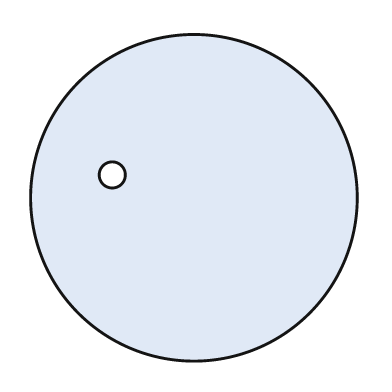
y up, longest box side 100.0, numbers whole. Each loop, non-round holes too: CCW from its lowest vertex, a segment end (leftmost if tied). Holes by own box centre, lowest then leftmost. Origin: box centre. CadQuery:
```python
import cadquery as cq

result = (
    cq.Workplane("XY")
    .moveTo(0.0, 0.0)
    .circle(50.0)
    .moveTo(-25.0, 7.0)
    .circle(4.0)
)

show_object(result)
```